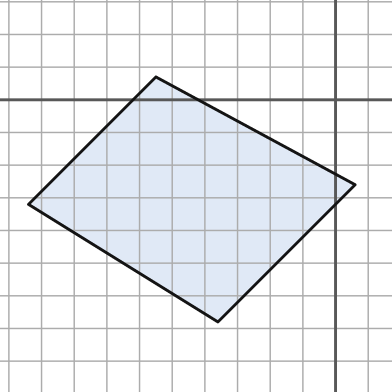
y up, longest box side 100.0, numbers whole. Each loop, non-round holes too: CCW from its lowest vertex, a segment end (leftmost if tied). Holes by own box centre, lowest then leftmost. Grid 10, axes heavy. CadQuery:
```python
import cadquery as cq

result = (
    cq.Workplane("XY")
    .moveTo(-36.0, -68.0)
    .lineTo(6.0, -26.0)
    .lineTo(-55.0, 7.0)
    .lineTo(-94.0, -32.0)
    .close()
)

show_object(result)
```